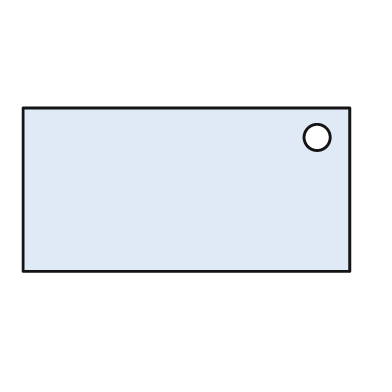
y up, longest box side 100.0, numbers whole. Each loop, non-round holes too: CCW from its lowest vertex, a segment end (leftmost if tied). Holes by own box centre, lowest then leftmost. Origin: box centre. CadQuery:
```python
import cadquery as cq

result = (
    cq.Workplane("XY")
    .moveTo(-50.0, -25.0)
    .lineTo(50.0, -25.0)
    .lineTo(50.0, 25.0)
    .lineTo(-50.0, 25.0)
    .close()
    .moveTo(40.0, 16.0)
    .circle(4.0)
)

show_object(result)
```